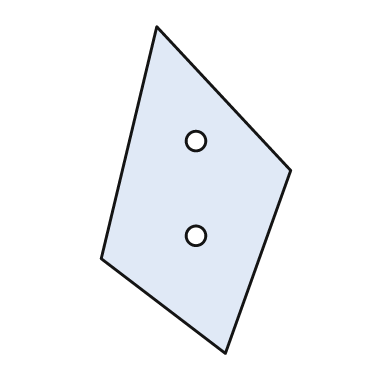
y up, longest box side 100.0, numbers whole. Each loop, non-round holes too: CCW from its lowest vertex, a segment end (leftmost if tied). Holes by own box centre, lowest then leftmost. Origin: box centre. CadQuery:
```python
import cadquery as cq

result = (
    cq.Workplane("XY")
    .moveTo(9.0, -50.0)
    .lineTo(29.0, 6.0)
    .lineTo(-12.0, 50.0)
    .lineTo(-29.0, -21.0)
    .close()
    .moveTo(0.0, -14.0)
    .circle(3.0)
    .moveTo(0.0, 15.0)
    .circle(3.0)
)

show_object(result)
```